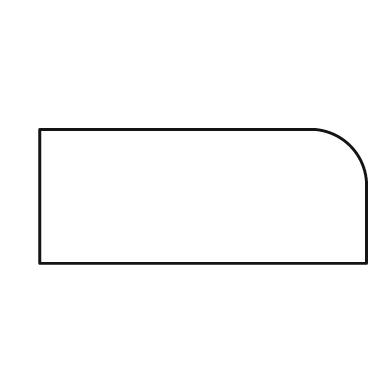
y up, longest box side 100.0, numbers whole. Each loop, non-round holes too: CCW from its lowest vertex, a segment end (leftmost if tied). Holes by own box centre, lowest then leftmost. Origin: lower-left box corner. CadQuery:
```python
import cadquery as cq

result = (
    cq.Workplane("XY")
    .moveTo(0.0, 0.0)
    .lineTo(100.0, 0.0)
    .lineTo(100.0, 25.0)
    .threePointArc((95.0, 36.0), (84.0, 41.0))
    .lineTo(0.0, 41.0)
    .close()
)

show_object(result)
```